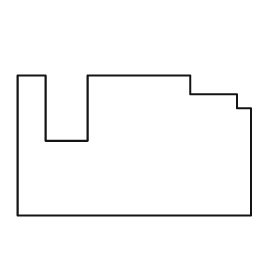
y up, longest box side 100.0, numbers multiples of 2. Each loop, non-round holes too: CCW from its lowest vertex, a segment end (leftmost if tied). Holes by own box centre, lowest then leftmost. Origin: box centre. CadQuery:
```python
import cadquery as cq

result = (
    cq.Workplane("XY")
    .moveTo(-50.0, -30.0)
    .lineTo(50.0, -30.0)
    .lineTo(50.0, 16.0)
    .lineTo(44.0, 16.0)
    .lineTo(44.0, 22.0)
    .lineTo(24.0, 22.0)
    .lineTo(24.0, 30.0)
    .lineTo(-20.0, 30.0)
    .lineTo(-20.0, 2.0)
    .lineTo(-38.0, 2.0)
    .lineTo(-38.0, 30.0)
    .lineTo(-50.0, 30.0)
    .close()
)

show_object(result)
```